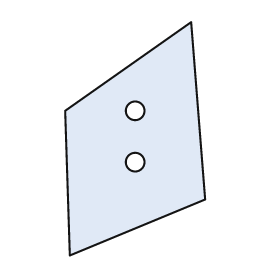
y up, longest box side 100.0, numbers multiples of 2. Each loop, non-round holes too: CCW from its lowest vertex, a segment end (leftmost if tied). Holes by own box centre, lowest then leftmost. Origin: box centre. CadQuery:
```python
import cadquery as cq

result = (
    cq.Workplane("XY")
    .moveTo(-28.0, -50.0)
    .lineTo(30.0, -26.0)
    .lineTo(24.0, 50.0)
    .lineTo(-30.0, 12.0)
    .close()
    .moveTo(0.0, -10.0)
    .circle(4.0)
    .moveTo(0.0, 12.0)
    .circle(4.0)
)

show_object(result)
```